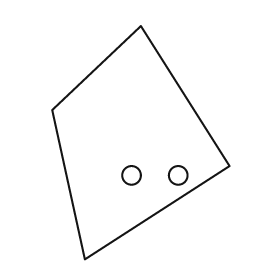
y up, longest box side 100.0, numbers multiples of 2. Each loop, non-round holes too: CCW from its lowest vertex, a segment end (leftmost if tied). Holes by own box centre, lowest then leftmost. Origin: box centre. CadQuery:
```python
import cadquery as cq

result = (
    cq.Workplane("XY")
    .moveTo(-24.0, -50.0)
    .lineTo(38.0, -10.0)
    .lineTo(0.0, 50.0)
    .lineTo(-38.0, 14.0)
    .close()
    .moveTo(-4.0, -14.0)
    .circle(4.0)
    .moveTo(16.0, -14.0)
    .circle(4.0)
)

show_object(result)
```